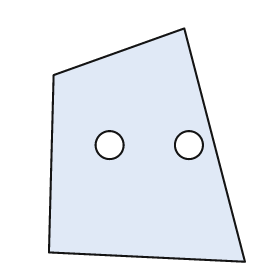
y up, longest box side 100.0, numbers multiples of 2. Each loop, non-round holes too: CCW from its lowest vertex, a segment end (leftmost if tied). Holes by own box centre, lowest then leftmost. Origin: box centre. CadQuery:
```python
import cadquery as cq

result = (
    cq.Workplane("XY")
    .moveTo(42.0, -50.0)
    .lineTo(16.0, 50.0)
    .lineTo(-40.0, 30.0)
    .lineTo(-42.0, -46.0)
    .close()
    .moveTo(-16.0, 0.0)
    .circle(6.0)
    .moveTo(18.0, 0.0)
    .circle(6.0)
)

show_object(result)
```